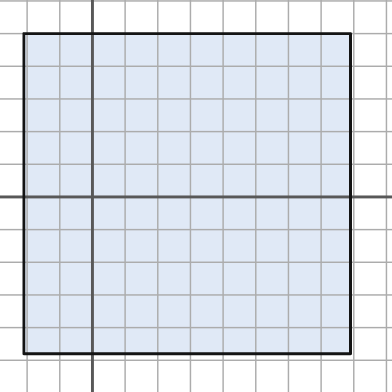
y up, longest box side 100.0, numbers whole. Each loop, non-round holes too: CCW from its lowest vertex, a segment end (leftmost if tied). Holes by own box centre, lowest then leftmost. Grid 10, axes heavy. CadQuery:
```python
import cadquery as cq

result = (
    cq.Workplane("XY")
    .moveTo(-21.0, -48.0)
    .lineTo(79.0, -48.0)
    .lineTo(79.0, 50.0)
    .lineTo(-21.0, 50.0)
    .close()
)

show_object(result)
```